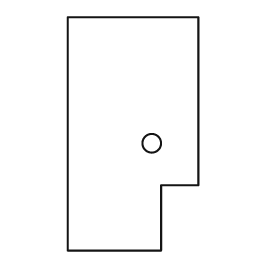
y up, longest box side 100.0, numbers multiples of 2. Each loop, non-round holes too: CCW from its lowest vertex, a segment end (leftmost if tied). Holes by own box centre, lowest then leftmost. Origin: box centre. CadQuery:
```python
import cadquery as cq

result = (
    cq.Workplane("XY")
    .moveTo(-28.0, -50.0)
    .lineTo(12.0, -50.0)
    .lineTo(12.0, -22.0)
    .lineTo(28.0, -22.0)
    .lineTo(28.0, 50.0)
    .lineTo(-28.0, 50.0)
    .close()
    .moveTo(8.0, -4.0)
    .circle(4.0)
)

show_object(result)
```